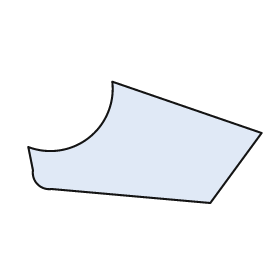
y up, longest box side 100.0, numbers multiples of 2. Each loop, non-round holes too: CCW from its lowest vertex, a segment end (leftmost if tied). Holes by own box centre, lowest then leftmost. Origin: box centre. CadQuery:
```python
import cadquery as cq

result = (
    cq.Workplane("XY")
    .moveTo(28.0, -26.0)
    .lineTo(50.0, 4.0)
    .lineTo(-14.0, 26.0)
    .threePointArc((-24.0, 2.0), (-50.0, -2.0))
    .lineTo(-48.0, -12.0)
    .threePointArc((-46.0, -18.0), (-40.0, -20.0))
    .close()
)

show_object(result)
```